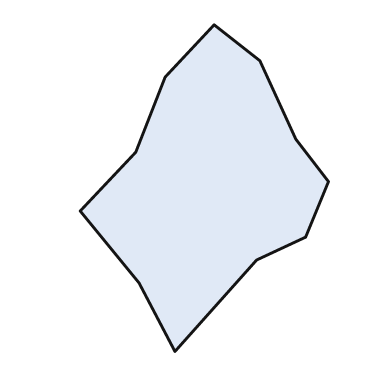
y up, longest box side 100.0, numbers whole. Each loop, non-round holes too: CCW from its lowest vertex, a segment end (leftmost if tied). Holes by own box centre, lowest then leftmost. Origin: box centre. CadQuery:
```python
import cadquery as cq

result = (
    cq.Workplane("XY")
    .moveTo(-9.0, -50.0)
    .lineTo(16.0, -22.0)
    .lineTo(31.0, -15.0)
    .lineTo(38.0, 2.0)
    .lineTo(28.0, 15.0)
    .lineTo(17.0, 39.0)
    .lineTo(3.0, 50.0)
    .lineTo(-12.0, 34.0)
    .lineTo(-21.0, 11.0)
    .lineTo(-38.0, -7.0)
    .lineTo(-20.0, -29.0)
    .close()
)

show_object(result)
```